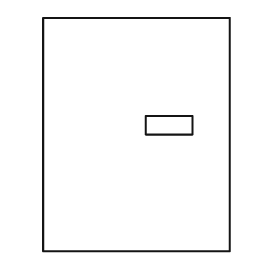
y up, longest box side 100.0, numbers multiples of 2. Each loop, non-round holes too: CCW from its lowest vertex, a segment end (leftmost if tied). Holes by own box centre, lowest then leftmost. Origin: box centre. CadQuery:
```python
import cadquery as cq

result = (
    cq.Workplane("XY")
    .moveTo(-40.0, -50.0)
    .lineTo(40.0, -50.0)
    .lineTo(40.0, 50.0)
    .lineTo(-40.0, 50.0)
    .close()
    .moveTo(4.0, 0.0)
    .lineTo(24.0, 0.0)
    .lineTo(24.0, 8.0)
    .lineTo(4.0, 8.0)
    .close()
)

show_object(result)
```